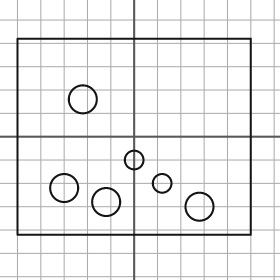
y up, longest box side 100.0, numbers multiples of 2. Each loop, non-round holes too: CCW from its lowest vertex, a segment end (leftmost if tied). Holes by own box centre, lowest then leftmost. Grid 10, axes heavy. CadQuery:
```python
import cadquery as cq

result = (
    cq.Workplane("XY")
    .moveTo(-50.0, -42.0)
    .lineTo(50.0, -42.0)
    .lineTo(50.0, 42.0)
    .lineTo(-50.0, 42.0)
    .close()
    .moveTo(28.0, -30.0)
    .circle(6.0)
    .moveTo(-12.0, -28.0)
    .circle(6.0)
    .moveTo(-30.0, -22.0)
    .circle(6.0)
    .moveTo(12.0, -20.0)
    .circle(4.0)
    .moveTo(0.0, -10.0)
    .circle(4.0)
    .moveTo(-22.0, 16.0)
    .circle(6.0)
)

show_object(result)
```